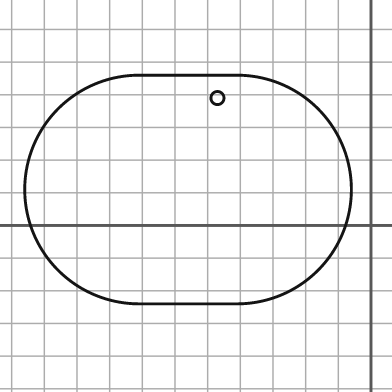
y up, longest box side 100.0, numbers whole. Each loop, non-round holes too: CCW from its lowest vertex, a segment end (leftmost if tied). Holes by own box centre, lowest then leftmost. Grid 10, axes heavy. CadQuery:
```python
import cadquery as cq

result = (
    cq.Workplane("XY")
    .moveTo(-71.0, -24.0)
    .lineTo(-41.0, -24.0)
    .threePointArc((-6.0, 11.0), (-41.0, 46.0))
    .lineTo(-71.0, 46.0)
    .threePointArc((-106.0, 11.0), (-71.0, -24.0))
    .close()
    .moveTo(-47.0, 39.0)
    .circle(2.0)
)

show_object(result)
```